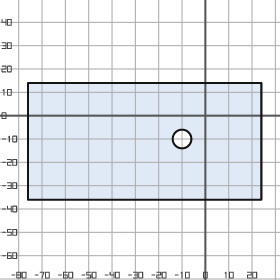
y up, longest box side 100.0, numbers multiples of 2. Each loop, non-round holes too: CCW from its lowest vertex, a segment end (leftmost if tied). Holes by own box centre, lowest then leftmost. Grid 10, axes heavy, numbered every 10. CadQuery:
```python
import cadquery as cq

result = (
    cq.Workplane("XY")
    .moveTo(-76.0, -36.0)
    .lineTo(24.0, -36.0)
    .lineTo(24.0, 14.0)
    .lineTo(-76.0, 14.0)
    .close()
    .moveTo(-10.0, -10.0)
    .circle(4.0)
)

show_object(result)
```